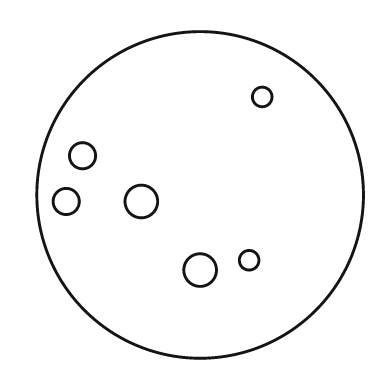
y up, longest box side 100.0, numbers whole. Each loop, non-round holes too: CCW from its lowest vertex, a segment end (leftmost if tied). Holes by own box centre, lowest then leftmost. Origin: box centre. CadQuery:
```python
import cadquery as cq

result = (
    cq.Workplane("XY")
    .moveTo(0.0, 0.0)
    .circle(50.0)
    .moveTo(0.0, -23.0)
    .circle(5.0)
    .moveTo(15.0, -20.0)
    .circle(3.0)
    .moveTo(-41.0, -2.0)
    .circle(4.0)
    .moveTo(-18.0, -2.0)
    .circle(5.0)
    .moveTo(-36.0, 12.0)
    .circle(4.0)
    .moveTo(19.0, 30.0)
    .circle(3.0)
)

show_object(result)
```